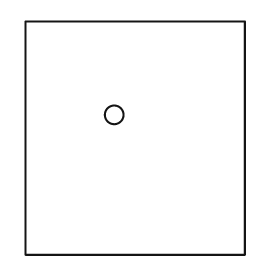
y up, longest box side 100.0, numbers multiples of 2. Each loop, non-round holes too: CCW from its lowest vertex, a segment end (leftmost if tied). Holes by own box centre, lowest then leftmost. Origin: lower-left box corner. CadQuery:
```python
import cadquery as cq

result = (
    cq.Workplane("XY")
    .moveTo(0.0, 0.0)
    .lineTo(94.0, 0.0)
    .lineTo(94.0, 100.0)
    .lineTo(0.0, 100.0)
    .close()
    .moveTo(38.0, 60.0)
    .circle(4.0)
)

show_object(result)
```